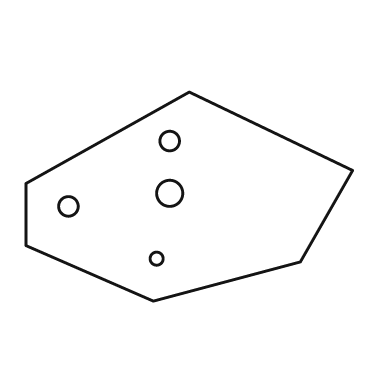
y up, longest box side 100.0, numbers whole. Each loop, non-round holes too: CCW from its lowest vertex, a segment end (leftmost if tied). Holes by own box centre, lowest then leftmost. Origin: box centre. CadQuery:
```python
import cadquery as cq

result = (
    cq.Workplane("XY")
    .moveTo(-11.0, -32.0)
    .lineTo(34.0, -20.0)
    .lineTo(50.0, 8.0)
    .lineTo(0.0, 32.0)
    .lineTo(-50.0, 4.0)
    .lineTo(-50.0, -15.0)
    .close()
    .moveTo(-10.0, -19.0)
    .circle(2.0)
    .moveTo(-37.0, -3.0)
    .circle(3.0)
    .moveTo(-6.0, 1.0)
    .circle(4.0)
    .moveTo(-6.0, 17.0)
    .circle(3.0)
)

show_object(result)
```